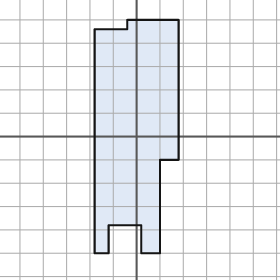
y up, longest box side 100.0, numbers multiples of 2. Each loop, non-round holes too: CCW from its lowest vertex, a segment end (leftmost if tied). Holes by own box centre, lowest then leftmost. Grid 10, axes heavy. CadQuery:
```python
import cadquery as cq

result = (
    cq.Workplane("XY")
    .moveTo(-18.0, -50.0)
    .lineTo(-12.0, -50.0)
    .lineTo(-12.0, -38.0)
    .lineTo(2.0, -38.0)
    .lineTo(2.0, -50.0)
    .lineTo(10.0, -50.0)
    .lineTo(10.0, -10.0)
    .lineTo(18.0, -10.0)
    .lineTo(18.0, 50.0)
    .lineTo(-4.0, 50.0)
    .lineTo(-4.0, 46.0)
    .lineTo(-18.0, 46.0)
    .close()
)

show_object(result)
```